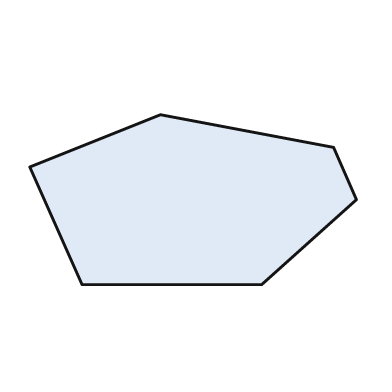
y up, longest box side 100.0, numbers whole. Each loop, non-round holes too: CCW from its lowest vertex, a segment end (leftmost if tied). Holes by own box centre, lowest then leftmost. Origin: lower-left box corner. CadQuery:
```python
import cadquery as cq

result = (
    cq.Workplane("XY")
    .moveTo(16.0, 0.0)
    .lineTo(71.0, 0.0)
    .lineTo(100.0, 26.0)
    .lineTo(93.0, 42.0)
    .lineTo(40.0, 52.0)
    .lineTo(0.0, 36.0)
    .close()
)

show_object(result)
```